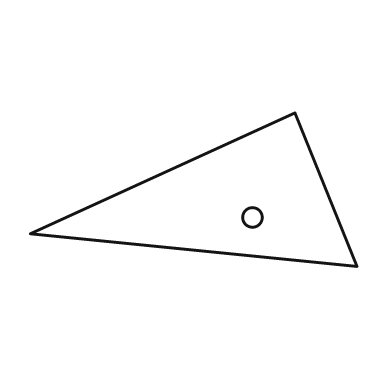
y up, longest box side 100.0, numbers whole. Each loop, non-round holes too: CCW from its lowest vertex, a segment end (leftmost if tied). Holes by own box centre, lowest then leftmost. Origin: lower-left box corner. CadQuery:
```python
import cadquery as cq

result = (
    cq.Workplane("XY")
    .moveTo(100.0, 0.0)
    .lineTo(81.0, 47.0)
    .lineTo(0.0, 10.0)
    .close()
    .moveTo(68.0, 15.0)
    .circle(3.0)
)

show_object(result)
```